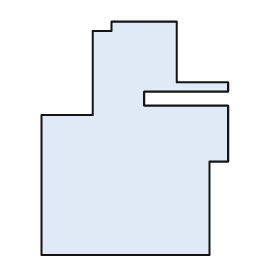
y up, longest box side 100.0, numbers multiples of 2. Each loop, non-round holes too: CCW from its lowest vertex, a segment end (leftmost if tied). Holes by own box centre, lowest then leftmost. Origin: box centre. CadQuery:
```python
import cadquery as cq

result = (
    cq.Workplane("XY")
    .moveTo(-40.0, -50.0)
    .lineTo(32.0, -50.0)
    .lineTo(32.0, -10.0)
    .lineTo(40.0, -10.0)
    .lineTo(40.0, 14.0)
    .lineTo(4.0, 14.0)
    .lineTo(4.0, 20.0)
    .lineTo(40.0, 20.0)
    .lineTo(40.0, 24.0)
    .lineTo(18.0, 24.0)
    .lineTo(18.0, 50.0)
    .lineTo(-10.0, 50.0)
    .lineTo(-10.0, 46.0)
    .lineTo(-18.0, 46.0)
    .lineTo(-18.0, 10.0)
    .lineTo(-40.0, 10.0)
    .close()
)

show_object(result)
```